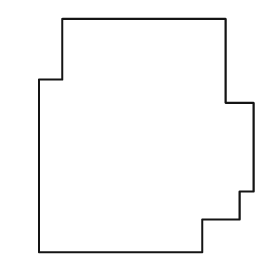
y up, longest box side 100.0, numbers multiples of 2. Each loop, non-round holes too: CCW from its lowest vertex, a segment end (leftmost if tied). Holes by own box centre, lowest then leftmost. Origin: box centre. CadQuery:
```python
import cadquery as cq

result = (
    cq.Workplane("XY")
    .moveTo(-46.0, -50.0)
    .lineTo(24.0, -50.0)
    .lineTo(24.0, -36.0)
    .lineTo(40.0, -36.0)
    .lineTo(40.0, -24.0)
    .lineTo(46.0, -24.0)
    .lineTo(46.0, 14.0)
    .lineTo(34.0, 14.0)
    .lineTo(34.0, 50.0)
    .lineTo(-36.0, 50.0)
    .lineTo(-36.0, 24.0)
    .lineTo(-46.0, 24.0)
    .close()
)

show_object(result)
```